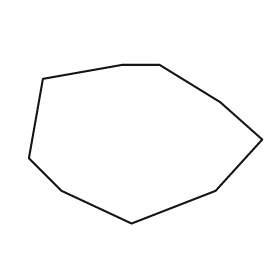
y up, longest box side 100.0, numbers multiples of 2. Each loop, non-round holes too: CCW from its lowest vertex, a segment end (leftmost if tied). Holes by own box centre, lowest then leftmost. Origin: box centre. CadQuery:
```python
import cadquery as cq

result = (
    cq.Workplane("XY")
    .moveTo(-6.0, -34.0)
    .lineTo(30.0, -20.0)
    .lineTo(50.0, 2.0)
    .lineTo(32.0, 18.0)
    .lineTo(6.0, 34.0)
    .lineTo(-10.0, 34.0)
    .lineTo(-44.0, 28.0)
    .lineTo(-50.0, -6.0)
    .lineTo(-36.0, -20.0)
    .close()
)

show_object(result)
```